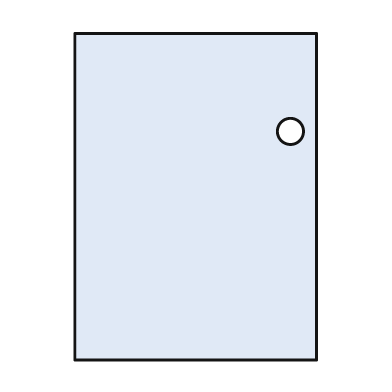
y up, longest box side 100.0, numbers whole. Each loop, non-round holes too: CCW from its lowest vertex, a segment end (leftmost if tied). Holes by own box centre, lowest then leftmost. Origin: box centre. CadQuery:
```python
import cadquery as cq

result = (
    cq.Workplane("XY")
    .moveTo(-37.0, -50.0)
    .lineTo(37.0, -50.0)
    .lineTo(37.0, 50.0)
    .lineTo(-37.0, 50.0)
    .close()
    .moveTo(29.0, 20.0)
    .circle(4.0)
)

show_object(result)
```